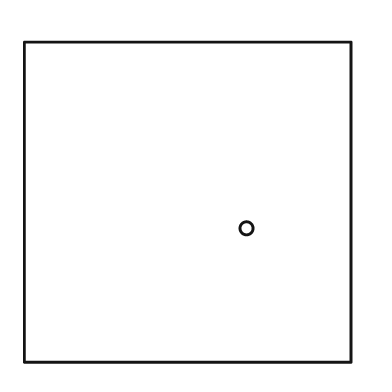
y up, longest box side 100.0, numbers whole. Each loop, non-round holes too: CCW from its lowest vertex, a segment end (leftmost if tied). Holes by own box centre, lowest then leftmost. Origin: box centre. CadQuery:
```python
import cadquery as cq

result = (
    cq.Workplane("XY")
    .moveTo(-50.0, -49.0)
    .lineTo(50.0, -49.0)
    .lineTo(50.0, 49.0)
    .lineTo(-50.0, 49.0)
    .close()
    .moveTo(18.0, -8.0)
    .circle(2.0)
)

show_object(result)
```